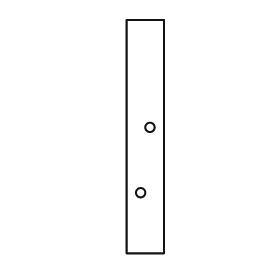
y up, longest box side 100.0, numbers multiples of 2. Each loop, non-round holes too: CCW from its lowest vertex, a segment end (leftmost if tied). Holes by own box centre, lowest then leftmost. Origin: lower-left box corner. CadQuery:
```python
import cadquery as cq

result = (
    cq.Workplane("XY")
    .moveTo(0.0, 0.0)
    .lineTo(16.0, 0.0)
    .lineTo(16.0, 100.0)
    .lineTo(0.0, 100.0)
    .close()
    .moveTo(6.0, 26.0)
    .circle(2.0)
    .moveTo(10.0, 54.0)
    .circle(2.0)
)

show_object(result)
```